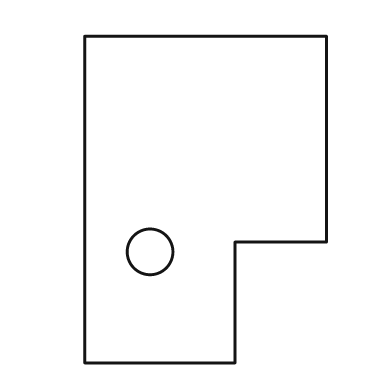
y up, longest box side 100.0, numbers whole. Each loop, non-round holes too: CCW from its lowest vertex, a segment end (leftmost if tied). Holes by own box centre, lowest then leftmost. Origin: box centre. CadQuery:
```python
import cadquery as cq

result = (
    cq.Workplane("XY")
    .moveTo(-37.0, -50.0)
    .lineTo(9.0, -50.0)
    .lineTo(9.0, -13.0)
    .lineTo(37.0, -13.0)
    .lineTo(37.0, 50.0)
    .lineTo(-37.0, 50.0)
    .close()
    .moveTo(-17.0, -16.0)
    .circle(7.0)
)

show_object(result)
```